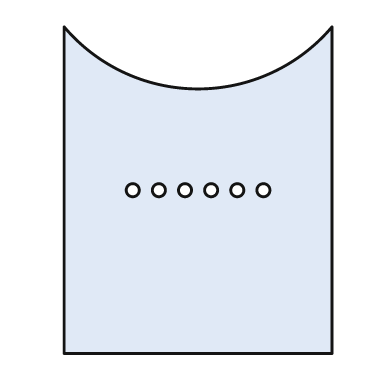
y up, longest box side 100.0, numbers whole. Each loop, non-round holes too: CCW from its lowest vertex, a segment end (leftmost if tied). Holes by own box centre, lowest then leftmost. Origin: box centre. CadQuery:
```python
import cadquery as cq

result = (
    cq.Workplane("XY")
    .moveTo(-41.0, -50.0)
    .lineTo(41.0, -50.0)
    .lineTo(41.0, 50.0)
    .threePointArc((0.0, 31.0), (-41.0, 50.0))
    .close()
    .moveTo(-20.0, 0.0)
    .circle(2.0)
    .moveTo(-12.0, 0.0)
    .circle(2.0)
    .moveTo(-4.0, 0.0)
    .circle(2.0)
    .moveTo(4.0, 0.0)
    .circle(2.0)
    .moveTo(12.0, 0.0)
    .circle(2.0)
    .moveTo(20.0, 0.0)
    .circle(2.0)
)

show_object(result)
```